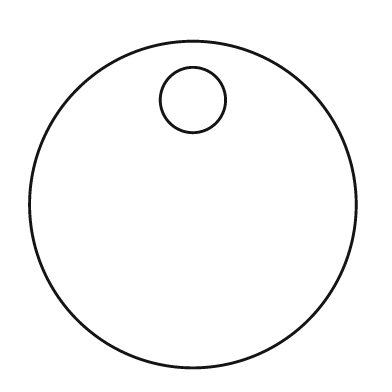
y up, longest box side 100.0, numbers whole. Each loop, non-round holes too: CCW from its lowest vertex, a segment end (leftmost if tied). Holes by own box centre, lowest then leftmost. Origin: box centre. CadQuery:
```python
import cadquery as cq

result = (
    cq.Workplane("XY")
    .moveTo(0.0, 0.0)
    .circle(50.0)
    .moveTo(0.0, 32.0)
    .circle(10.0)
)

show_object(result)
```